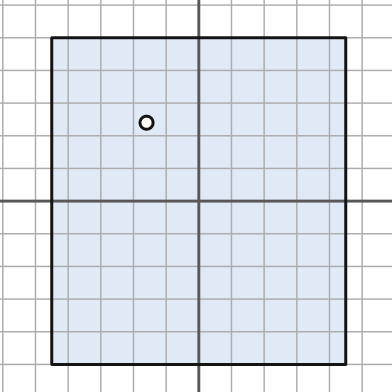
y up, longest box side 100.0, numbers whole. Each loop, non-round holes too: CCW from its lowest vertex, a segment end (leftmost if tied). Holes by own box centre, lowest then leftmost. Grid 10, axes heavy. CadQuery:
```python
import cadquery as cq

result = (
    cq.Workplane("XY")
    .moveTo(-45.0, -50.0)
    .lineTo(45.0, -50.0)
    .lineTo(45.0, 50.0)
    .lineTo(-45.0, 50.0)
    .close()
    .moveTo(-16.0, 24.0)
    .circle(2.0)
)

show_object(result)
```